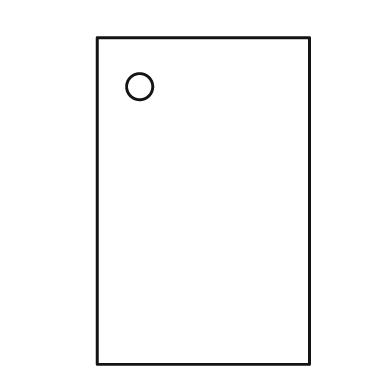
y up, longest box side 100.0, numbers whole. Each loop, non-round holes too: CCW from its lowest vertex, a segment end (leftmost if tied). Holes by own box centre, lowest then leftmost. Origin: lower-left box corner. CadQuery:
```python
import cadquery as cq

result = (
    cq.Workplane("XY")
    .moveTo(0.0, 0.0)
    .lineTo(65.0, 0.0)
    .lineTo(65.0, 100.0)
    .lineTo(0.0, 100.0)
    .close()
    .moveTo(13.0, 85.0)
    .circle(4.0)
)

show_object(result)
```